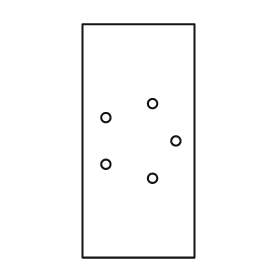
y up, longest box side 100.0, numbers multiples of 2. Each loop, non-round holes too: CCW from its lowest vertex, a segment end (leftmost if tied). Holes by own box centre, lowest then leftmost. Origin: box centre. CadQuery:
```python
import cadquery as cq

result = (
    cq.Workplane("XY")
    .moveTo(-24.0, -50.0)
    .lineTo(24.0, -50.0)
    .lineTo(24.0, 50.0)
    .lineTo(-24.0, 50.0)
    .close()
    .moveTo(6.0, -16.0)
    .circle(2.0)
    .moveTo(-14.0, -10.0)
    .circle(2.0)
    .moveTo(16.0, 0.0)
    .circle(2.0)
    .moveTo(-14.0, 10.0)
    .circle(2.0)
    .moveTo(6.0, 16.0)
    .circle(2.0)
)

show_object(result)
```